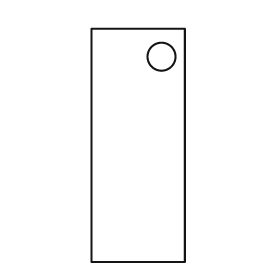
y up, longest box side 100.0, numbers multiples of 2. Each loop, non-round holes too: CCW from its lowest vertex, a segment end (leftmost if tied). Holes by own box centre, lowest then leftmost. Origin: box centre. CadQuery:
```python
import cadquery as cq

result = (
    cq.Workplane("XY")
    .moveTo(-20.0, -50.0)
    .lineTo(20.0, -50.0)
    .lineTo(20.0, 50.0)
    .lineTo(-20.0, 50.0)
    .close()
    .moveTo(10.0, 38.0)
    .circle(6.0)
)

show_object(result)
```